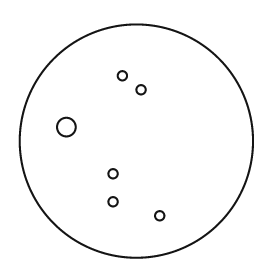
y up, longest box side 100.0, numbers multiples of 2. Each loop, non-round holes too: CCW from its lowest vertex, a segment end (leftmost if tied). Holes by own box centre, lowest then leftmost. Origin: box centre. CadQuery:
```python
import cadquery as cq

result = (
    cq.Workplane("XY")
    .moveTo(0.0, 0.0)
    .circle(50.0)
    .moveTo(10.0, -32.0)
    .circle(2.0)
    .moveTo(-10.0, -26.0)
    .circle(2.0)
    .moveTo(-10.0, -14.0)
    .circle(2.0)
    .moveTo(-30.0, 6.0)
    .circle(4.0)
    .moveTo(2.0, 22.0)
    .circle(2.0)
    .moveTo(-6.0, 28.0)
    .circle(2.0)
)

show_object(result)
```